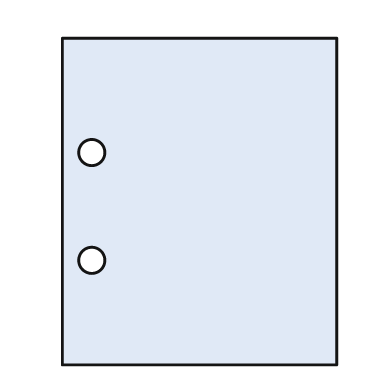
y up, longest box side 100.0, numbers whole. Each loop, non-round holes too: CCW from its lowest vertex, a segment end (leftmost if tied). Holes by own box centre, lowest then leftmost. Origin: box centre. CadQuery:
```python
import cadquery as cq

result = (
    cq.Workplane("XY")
    .moveTo(-42.0, -50.0)
    .lineTo(42.0, -50.0)
    .lineTo(42.0, 50.0)
    .lineTo(-42.0, 50.0)
    .close()
    .moveTo(-33.0, -18.0)
    .circle(4.0)
    .moveTo(-33.0, 15.0)
    .circle(4.0)
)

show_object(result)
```